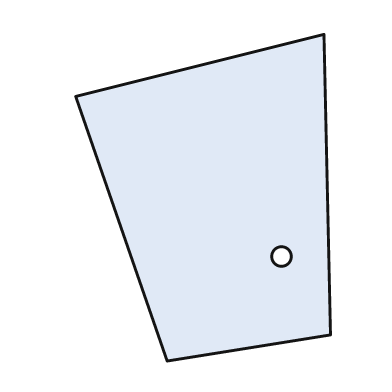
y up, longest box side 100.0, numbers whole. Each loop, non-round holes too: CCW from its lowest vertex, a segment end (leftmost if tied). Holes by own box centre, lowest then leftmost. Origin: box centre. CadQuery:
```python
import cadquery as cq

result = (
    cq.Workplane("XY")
    .moveTo(-11.0, -50.0)
    .lineTo(39.0, -42.0)
    .lineTo(37.0, 50.0)
    .lineTo(-39.0, 31.0)
    .close()
    .moveTo(24.0, -18.0)
    .circle(3.0)
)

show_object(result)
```